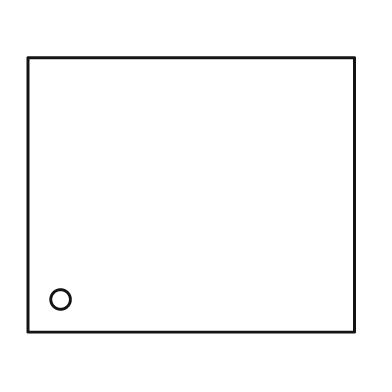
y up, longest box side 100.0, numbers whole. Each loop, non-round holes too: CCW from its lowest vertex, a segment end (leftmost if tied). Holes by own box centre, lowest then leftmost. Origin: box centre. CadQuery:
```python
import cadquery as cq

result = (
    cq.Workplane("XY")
    .moveTo(-50.0, -42.0)
    .lineTo(50.0, -42.0)
    .lineTo(50.0, 42.0)
    .lineTo(-50.0, 42.0)
    .close()
    .moveTo(-40.0, -32.0)
    .circle(3.0)
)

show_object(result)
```